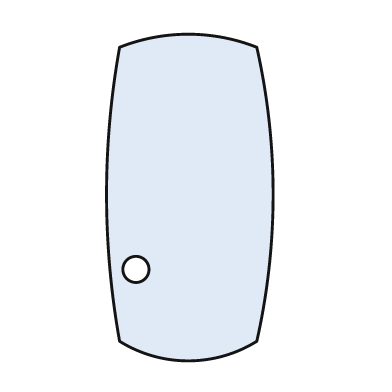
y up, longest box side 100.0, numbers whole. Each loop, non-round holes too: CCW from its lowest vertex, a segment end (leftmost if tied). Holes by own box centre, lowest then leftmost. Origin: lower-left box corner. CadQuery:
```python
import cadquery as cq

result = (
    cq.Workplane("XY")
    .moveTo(4.0, 6.0)
    .threePointArc((25.0, 0.0), (46.0, 6.0))
    .threePointArc((51.0, 51.0), (46.0, 96.0))
    .threePointArc((25.0, 100.0), (4.0, 96.0))
    .threePointArc((0.0, 51.0), (4.0, 6.0))
    .close()
    .moveTo(9.0, 28.0)
    .circle(4.0)
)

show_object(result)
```